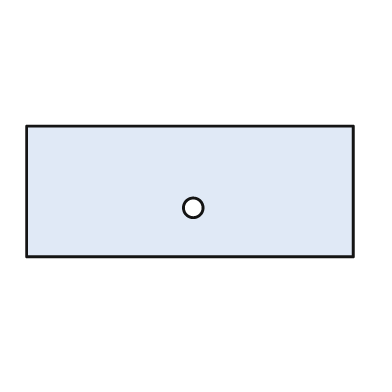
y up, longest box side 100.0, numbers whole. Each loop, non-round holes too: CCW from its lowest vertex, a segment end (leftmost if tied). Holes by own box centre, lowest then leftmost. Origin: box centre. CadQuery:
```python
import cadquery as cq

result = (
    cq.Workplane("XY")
    .moveTo(-50.0, -20.0)
    .lineTo(50.0, -20.0)
    .lineTo(50.0, 20.0)
    .lineTo(-50.0, 20.0)
    .close()
    .moveTo(1.0, -5.0)
    .circle(3.0)
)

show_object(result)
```